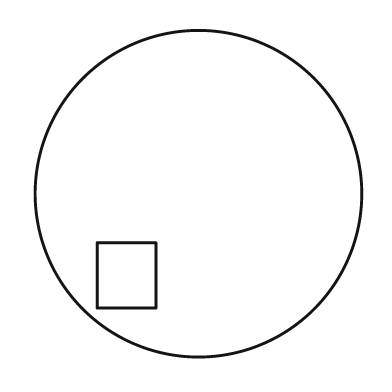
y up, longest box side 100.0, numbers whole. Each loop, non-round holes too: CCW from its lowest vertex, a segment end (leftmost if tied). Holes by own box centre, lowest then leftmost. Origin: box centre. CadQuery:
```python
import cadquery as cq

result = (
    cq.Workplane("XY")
    .moveTo(0.0, 0.0)
    .circle(50.0)
    .moveTo(-31.0, -35.0)
    .lineTo(-13.0, -35.0)
    .lineTo(-13.0, -15.0)
    .lineTo(-31.0, -15.0)
    .close()
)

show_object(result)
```